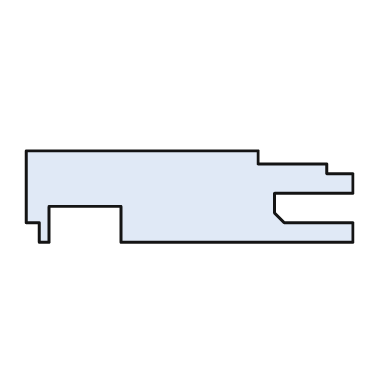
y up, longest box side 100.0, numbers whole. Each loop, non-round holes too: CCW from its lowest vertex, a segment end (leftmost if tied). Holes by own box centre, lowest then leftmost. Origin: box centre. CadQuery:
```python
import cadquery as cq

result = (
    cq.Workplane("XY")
    .moveTo(-46.0, -14.0)
    .lineTo(-43.0, -14.0)
    .lineTo(-43.0, -3.0)
    .lineTo(-21.0, -3.0)
    .lineTo(-21.0, -14.0)
    .lineTo(50.0, -14.0)
    .lineTo(50.0, -8.0)
    .lineTo(29.0, -8.0)
    .lineTo(26.0, -5.0)
    .lineTo(26.0, 1.0)
    .lineTo(50.0, 1.0)
    .lineTo(50.0, 7.0)
    .lineTo(42.0, 7.0)
    .lineTo(42.0, 10.0)
    .lineTo(21.0, 10.0)
    .lineTo(21.0, 14.0)
    .lineTo(-50.0, 14.0)
    .lineTo(-50.0, -8.0)
    .lineTo(-46.0, -8.0)
    .close()
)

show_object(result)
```